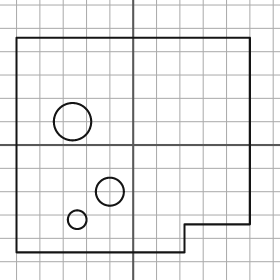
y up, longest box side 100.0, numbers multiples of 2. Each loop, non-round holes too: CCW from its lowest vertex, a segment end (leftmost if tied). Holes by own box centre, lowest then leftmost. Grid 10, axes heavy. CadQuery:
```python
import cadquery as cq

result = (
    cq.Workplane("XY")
    .moveTo(-50.0, -46.0)
    .lineTo(22.0, -46.0)
    .lineTo(22.0, -34.0)
    .lineTo(50.0, -34.0)
    .lineTo(50.0, 46.0)
    .lineTo(-50.0, 46.0)
    .close()
    .moveTo(-24.0, -32.0)
    .circle(4.0)
    .moveTo(-10.0, -20.0)
    .circle(6.0)
    .moveTo(-26.0, 10.0)
    .circle(8.0)
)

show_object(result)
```